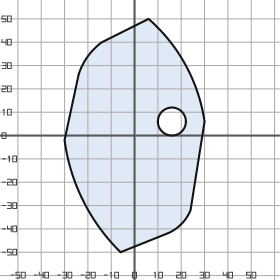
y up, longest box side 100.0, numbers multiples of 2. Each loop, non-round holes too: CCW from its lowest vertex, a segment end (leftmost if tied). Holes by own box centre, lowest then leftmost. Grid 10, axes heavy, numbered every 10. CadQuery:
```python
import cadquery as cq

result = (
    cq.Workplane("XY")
    .moveTo(-6.0, -50.0)
    .lineTo(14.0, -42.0)
    .threePointArc((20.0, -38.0), (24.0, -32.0))
    .lineTo(30.0, 6.0)
    .threePointArc((22.0, 30.0), (6.0, 50.0))
    .lineTo(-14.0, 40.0)
    .threePointArc((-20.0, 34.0), (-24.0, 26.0))
    .lineTo(-30.0, -2.0)
    .threePointArc((-22.0, -28.0), (-6.0, -50.0))
    .close()
    .moveTo(16.0, 6.0)
    .circle(6.0)
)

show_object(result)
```